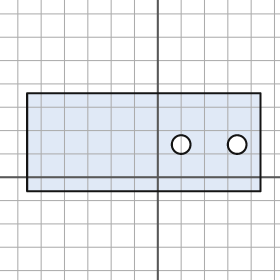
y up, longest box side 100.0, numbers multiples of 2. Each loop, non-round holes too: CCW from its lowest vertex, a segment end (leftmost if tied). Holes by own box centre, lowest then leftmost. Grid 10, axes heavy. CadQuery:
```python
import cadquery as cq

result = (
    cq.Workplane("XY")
    .moveTo(-56.0, -6.0)
    .lineTo(44.0, -6.0)
    .lineTo(44.0, 36.0)
    .lineTo(-56.0, 36.0)
    .close()
    .moveTo(10.0, 14.0)
    .circle(4.0)
    .moveTo(34.0, 14.0)
    .circle(4.0)
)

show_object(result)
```